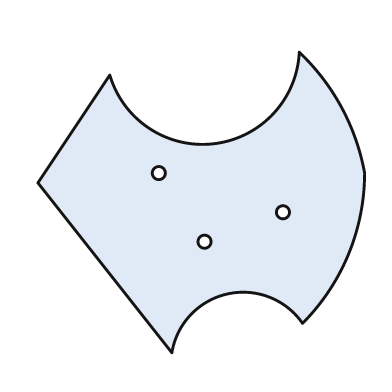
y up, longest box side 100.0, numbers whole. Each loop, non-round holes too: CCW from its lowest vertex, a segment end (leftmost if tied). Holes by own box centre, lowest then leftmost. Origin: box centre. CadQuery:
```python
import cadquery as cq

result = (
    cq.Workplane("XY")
    .moveTo(-9.0, -46.0)
    .threePointArc((8.0, -28.0), (31.0, -37.0))
    .threePointArc((45.0, -16.0), (50.0, 9.0))
    .threePointArc((43.0, 29.0), (30.0, 46.0))
    .threePointArc((4.0, 18.0), (-28.0, 39.0))
    .lineTo(-50.0, 6.0)
    .close()
    .moveTo(1.0, -12.0)
    .circle(2.0)
    .moveTo(25.0, -3.0)
    .circle(2.0)
    .moveTo(-13.0, 9.0)
    .circle(2.0)
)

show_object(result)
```